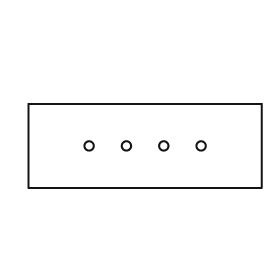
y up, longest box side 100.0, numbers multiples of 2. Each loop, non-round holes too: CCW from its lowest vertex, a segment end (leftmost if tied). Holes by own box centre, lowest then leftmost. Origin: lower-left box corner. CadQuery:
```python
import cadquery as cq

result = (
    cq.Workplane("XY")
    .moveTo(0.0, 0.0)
    .lineTo(100.0, 0.0)
    .lineTo(100.0, 36.0)
    .lineTo(0.0, 36.0)
    .close()
    .moveTo(26.0, 18.0)
    .circle(2.0)
    .moveTo(42.0, 18.0)
    .circle(2.0)
    .moveTo(58.0, 18.0)
    .circle(2.0)
    .moveTo(74.0, 18.0)
    .circle(2.0)
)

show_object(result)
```